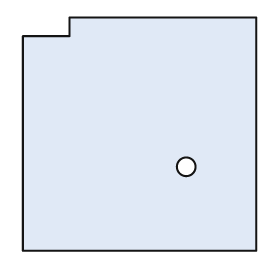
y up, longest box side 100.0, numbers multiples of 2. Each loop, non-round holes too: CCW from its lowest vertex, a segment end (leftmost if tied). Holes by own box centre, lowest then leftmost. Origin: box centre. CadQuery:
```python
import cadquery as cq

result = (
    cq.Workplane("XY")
    .moveTo(-50.0, -50.0)
    .lineTo(50.0, -50.0)
    .lineTo(50.0, 50.0)
    .lineTo(-30.0, 50.0)
    .lineTo(-30.0, 42.0)
    .lineTo(-50.0, 42.0)
    .close()
    .moveTo(20.0, -14.0)
    .circle(4.0)
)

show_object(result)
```